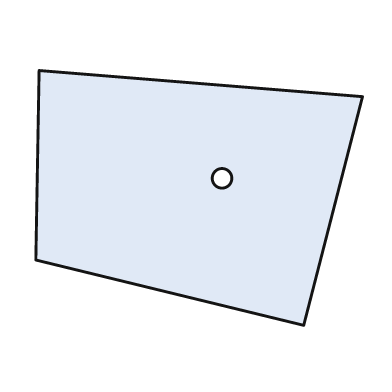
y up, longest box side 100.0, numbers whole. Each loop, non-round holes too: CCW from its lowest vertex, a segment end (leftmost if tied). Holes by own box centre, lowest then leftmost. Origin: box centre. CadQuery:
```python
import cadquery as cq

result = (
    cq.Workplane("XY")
    .moveTo(32.0, -39.0)
    .lineTo(50.0, 31.0)
    .lineTo(-49.0, 39.0)
    .lineTo(-50.0, -19.0)
    .close()
    .moveTo(7.0, 6.0)
    .circle(3.0)
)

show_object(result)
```